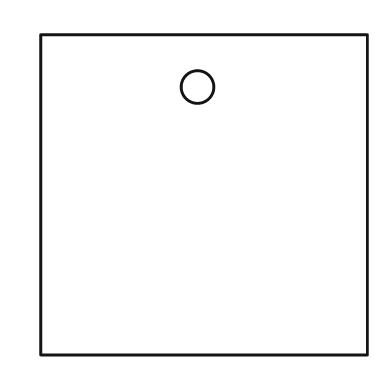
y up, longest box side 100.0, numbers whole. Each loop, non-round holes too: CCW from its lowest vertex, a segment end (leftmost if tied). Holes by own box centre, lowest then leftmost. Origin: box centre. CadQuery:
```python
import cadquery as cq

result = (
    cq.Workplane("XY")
    .moveTo(-50.0, -49.0)
    .lineTo(50.0, -49.0)
    .lineTo(50.0, 49.0)
    .lineTo(-50.0, 49.0)
    .close()
    .moveTo(-2.0, 33.0)
    .circle(5.0)
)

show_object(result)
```